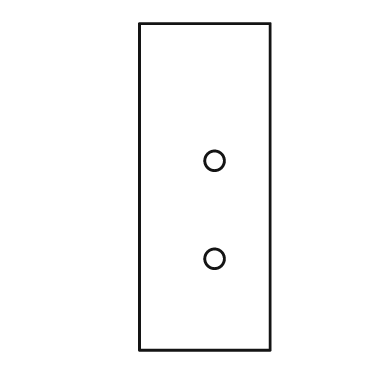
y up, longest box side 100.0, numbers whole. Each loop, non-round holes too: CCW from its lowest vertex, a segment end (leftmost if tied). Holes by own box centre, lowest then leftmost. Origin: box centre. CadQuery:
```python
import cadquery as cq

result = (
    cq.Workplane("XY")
    .moveTo(-20.0, -50.0)
    .lineTo(20.0, -50.0)
    .lineTo(20.0, 50.0)
    .lineTo(-20.0, 50.0)
    .close()
    .moveTo(3.0, -22.0)
    .circle(3.0)
    .moveTo(3.0, 8.0)
    .circle(3.0)
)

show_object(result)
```